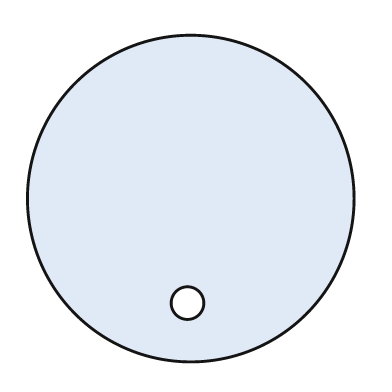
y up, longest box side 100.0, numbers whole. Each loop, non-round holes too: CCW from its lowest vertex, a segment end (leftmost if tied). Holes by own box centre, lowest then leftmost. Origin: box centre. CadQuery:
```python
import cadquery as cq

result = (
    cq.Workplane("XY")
    .moveTo(0.0, 0.0)
    .circle(50.0)
    .moveTo(-1.0, -32.0)
    .circle(5.0)
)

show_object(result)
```